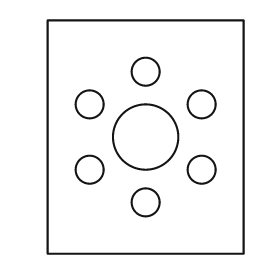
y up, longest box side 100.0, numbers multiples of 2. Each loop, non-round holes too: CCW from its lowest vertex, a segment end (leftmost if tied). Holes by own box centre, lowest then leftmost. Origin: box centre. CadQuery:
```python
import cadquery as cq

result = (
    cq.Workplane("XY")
    .moveTo(-42.0, -50.0)
    .lineTo(42.0, -50.0)
    .lineTo(42.0, 50.0)
    .lineTo(-42.0, 50.0)
    .close()
    .moveTo(0.0, -28.0)
    .circle(6.0)
    .moveTo(-24.0, -14.0)
    .circle(6.0)
    .moveTo(24.0, -14.0)
    .circle(6.0)
    .moveTo(0.0, 0.0)
    .circle(14.0)
    .moveTo(-24.0, 14.0)
    .circle(6.0)
    .moveTo(24.0, 14.0)
    .circle(6.0)
    .moveTo(0.0, 28.0)
    .circle(6.0)
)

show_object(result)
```